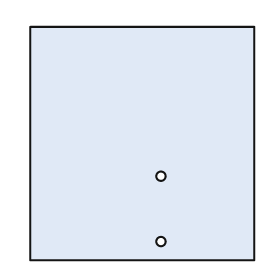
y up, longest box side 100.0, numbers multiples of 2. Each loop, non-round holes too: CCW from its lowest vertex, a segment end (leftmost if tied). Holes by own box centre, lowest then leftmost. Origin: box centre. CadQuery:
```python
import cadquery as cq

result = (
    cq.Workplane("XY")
    .moveTo(-48.0, -50.0)
    .lineTo(48.0, -50.0)
    .lineTo(48.0, 50.0)
    .lineTo(-48.0, 50.0)
    .close()
    .moveTo(8.0, -42.0)
    .circle(2.0)
    .moveTo(8.0, -14.0)
    .circle(2.0)
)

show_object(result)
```